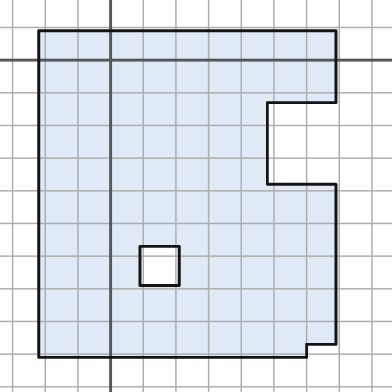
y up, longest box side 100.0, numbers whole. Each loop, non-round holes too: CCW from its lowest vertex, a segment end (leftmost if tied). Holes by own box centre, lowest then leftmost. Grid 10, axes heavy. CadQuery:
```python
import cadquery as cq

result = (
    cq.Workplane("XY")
    .moveTo(-22.0, -91.0)
    .lineTo(60.0, -91.0)
    .lineTo(60.0, -87.0)
    .lineTo(69.0, -87.0)
    .lineTo(69.0, -38.0)
    .lineTo(48.0, -38.0)
    .lineTo(48.0, -13.0)
    .lineTo(69.0, -13.0)
    .lineTo(69.0, 9.0)
    .lineTo(-22.0, 9.0)
    .close()
    .moveTo(9.0, -69.0)
    .lineTo(21.0, -69.0)
    .lineTo(21.0, -57.0)
    .lineTo(9.0, -57.0)
    .close()
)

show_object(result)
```